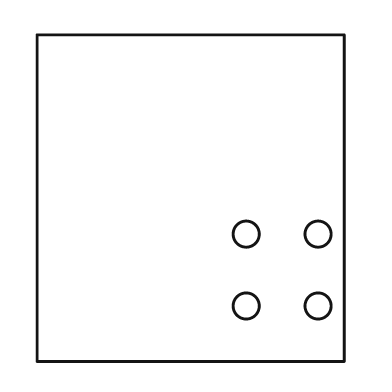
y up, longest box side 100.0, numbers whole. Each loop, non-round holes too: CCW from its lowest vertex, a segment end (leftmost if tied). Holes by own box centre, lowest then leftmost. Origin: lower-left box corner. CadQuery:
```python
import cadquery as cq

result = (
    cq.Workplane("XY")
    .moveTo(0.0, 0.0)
    .lineTo(94.0, 0.0)
    .lineTo(94.0, 100.0)
    .lineTo(0.0, 100.0)
    .close()
    .moveTo(64.0, 17.0)
    .circle(4.0)
    .moveTo(86.0, 17.0)
    .circle(4.0)
    .moveTo(64.0, 39.0)
    .circle(4.0)
    .moveTo(86.0, 39.0)
    .circle(4.0)
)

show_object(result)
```